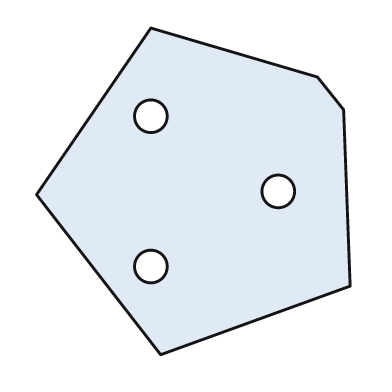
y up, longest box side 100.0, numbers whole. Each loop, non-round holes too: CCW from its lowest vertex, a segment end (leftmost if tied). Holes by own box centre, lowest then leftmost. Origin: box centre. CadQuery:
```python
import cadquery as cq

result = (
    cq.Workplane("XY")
    .moveTo(-10.0, -50.0)
    .lineTo(48.0, -29.0)
    .lineTo(46.0, 25.0)
    .lineTo(38.0, 35.0)
    .lineTo(-13.0, 50.0)
    .lineTo(-48.0, -1.0)
    .close()
    .moveTo(-13.0, -23.0)
    .circle(5.0)
    .moveTo(26.0, 0.0)
    .circle(5.0)
    .moveTo(-13.0, 23.0)
    .circle(5.0)
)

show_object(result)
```